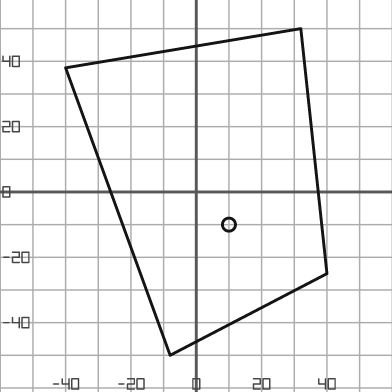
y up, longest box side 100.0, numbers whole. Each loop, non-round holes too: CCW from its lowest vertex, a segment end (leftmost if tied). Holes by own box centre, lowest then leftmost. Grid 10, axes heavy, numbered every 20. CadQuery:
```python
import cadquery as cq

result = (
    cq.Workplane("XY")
    .moveTo(-8.0, -50.0)
    .lineTo(40.0, -25.0)
    .lineTo(32.0, 50.0)
    .lineTo(-40.0, 38.0)
    .close()
    .moveTo(10.0, -10.0)
    .circle(2.0)
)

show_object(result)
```